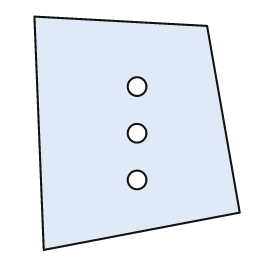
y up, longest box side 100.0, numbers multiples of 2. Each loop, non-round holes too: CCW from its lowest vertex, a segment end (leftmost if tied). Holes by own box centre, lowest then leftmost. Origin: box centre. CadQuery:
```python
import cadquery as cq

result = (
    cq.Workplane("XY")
    .moveTo(-40.0, -50.0)
    .lineTo(44.0, -34.0)
    .lineTo(30.0, 46.0)
    .lineTo(-44.0, 50.0)
    .close()
    .moveTo(0.0, -20.0)
    .circle(4.0)
    .moveTo(0.0, 0.0)
    .circle(4.0)
    .moveTo(0.0, 20.0)
    .circle(4.0)
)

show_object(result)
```